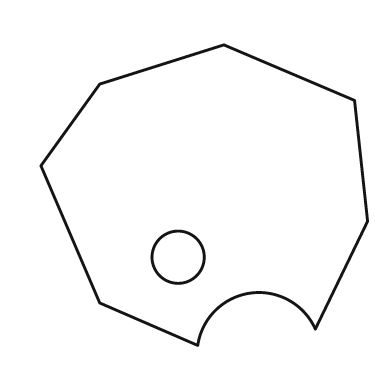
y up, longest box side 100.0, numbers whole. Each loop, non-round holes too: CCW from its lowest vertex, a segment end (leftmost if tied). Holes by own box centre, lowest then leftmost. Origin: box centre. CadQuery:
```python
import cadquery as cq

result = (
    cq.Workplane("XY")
    .moveTo(-2.0, -46.0)
    .threePointArc((14.0, -30.0), (34.0, -41.0))
    .lineTo(50.0, -8.0)
    .lineTo(46.0, 29.0)
    .lineTo(6.0, 46.0)
    .lineTo(-32.0, 34.0)
    .lineTo(-50.0, 9.0)
    .lineTo(-32.0, -33.0)
    .close()
    .moveTo(-8.0, -19.0)
    .circle(8.0)
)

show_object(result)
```